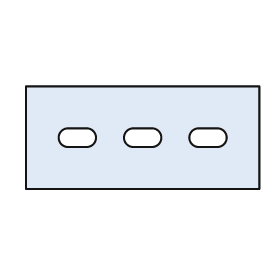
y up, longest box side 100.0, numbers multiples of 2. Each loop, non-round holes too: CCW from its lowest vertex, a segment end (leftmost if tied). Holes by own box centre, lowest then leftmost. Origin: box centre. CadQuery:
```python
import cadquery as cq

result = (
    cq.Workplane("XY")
    .moveTo(-50.0, -22.0)
    .lineTo(50.0, -22.0)
    .lineTo(50.0, 22.0)
    .lineTo(-50.0, 22.0)
    .close()
    .moveTo(-32.0, -4.0)
    .lineTo(-24.0, -4.0)
    .threePointArc((-20.0, 0.0), (-24.0, 4.0))
    .lineTo(-32.0, 4.0)
    .threePointArc((-36.0, 0.0), (-32.0, -4.0))
    .close()
    .moveTo(-4.0, -4.0)
    .lineTo(4.0, -4.0)
    .threePointArc((8.0, 0.0), (4.0, 4.0))
    .lineTo(-4.0, 4.0)
    .threePointArc((-8.0, 0.0), (-4.0, -4.0))
    .close()
    .moveTo(24.0, -4.0)
    .lineTo(32.0, -4.0)
    .threePointArc((36.0, 0.0), (32.0, 4.0))
    .lineTo(24.0, 4.0)
    .threePointArc((20.0, 0.0), (24.0, -4.0))
    .close()
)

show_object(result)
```